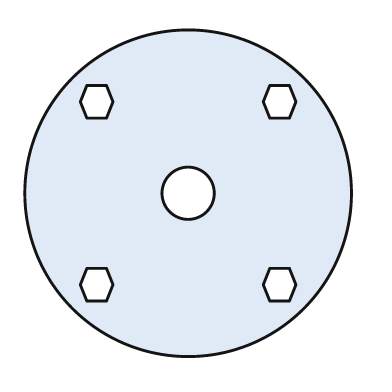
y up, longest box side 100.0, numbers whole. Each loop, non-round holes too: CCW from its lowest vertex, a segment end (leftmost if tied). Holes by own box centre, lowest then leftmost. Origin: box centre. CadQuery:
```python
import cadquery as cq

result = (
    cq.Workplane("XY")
    .moveTo(0.0, 0.0)
    .circle(50.0)
    .moveTo(-31.0, -33.0)
    .lineTo(-25.0, -33.0)
    .lineTo(-23.0, -28.0)
    .lineTo(-25.0, -23.0)
    .lineTo(-31.0, -23.0)
    .lineTo(-33.0, -28.0)
    .close()
    .moveTo(25.0, -33.0)
    .lineTo(31.0, -33.0)
    .lineTo(33.0, -28.0)
    .lineTo(31.0, -23.0)
    .lineTo(25.0, -23.0)
    .lineTo(23.0, -28.0)
    .close()
    .moveTo(0.0, 0.0)
    .circle(8.0)
    .moveTo(-31.0, 23.0)
    .lineTo(-25.0, 23.0)
    .lineTo(-23.0, 28.0)
    .lineTo(-25.0, 33.0)
    .lineTo(-31.0, 33.0)
    .lineTo(-33.0, 28.0)
    .close()
    .moveTo(25.0, 23.0)
    .lineTo(31.0, 23.0)
    .lineTo(33.0, 28.0)
    .lineTo(31.0, 33.0)
    .lineTo(25.0, 33.0)
    .lineTo(23.0, 28.0)
    .close()
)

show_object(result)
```